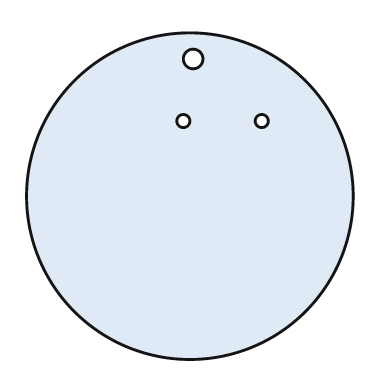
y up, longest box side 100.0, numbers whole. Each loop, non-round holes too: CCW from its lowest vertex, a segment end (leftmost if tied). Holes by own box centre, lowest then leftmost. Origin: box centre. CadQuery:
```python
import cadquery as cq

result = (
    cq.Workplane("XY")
    .moveTo(0.0, 0.0)
    .circle(50.0)
    .moveTo(-2.0, 23.0)
    .circle(2.0)
    .moveTo(22.0, 23.0)
    .circle(2.0)
    .moveTo(1.0, 42.0)
    .circle(3.0)
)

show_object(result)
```